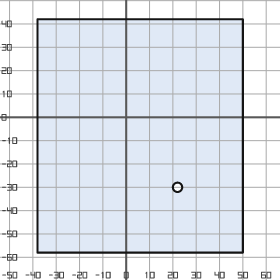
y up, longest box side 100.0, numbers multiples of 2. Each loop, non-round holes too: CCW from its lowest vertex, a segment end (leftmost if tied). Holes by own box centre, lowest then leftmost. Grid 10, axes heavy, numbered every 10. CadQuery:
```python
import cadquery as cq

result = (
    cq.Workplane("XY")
    .moveTo(-38.0, -58.0)
    .lineTo(50.0, -58.0)
    .lineTo(50.0, 42.0)
    .lineTo(-38.0, 42.0)
    .close()
    .moveTo(22.0, -30.0)
    .circle(2.0)
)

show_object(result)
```